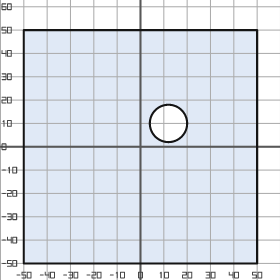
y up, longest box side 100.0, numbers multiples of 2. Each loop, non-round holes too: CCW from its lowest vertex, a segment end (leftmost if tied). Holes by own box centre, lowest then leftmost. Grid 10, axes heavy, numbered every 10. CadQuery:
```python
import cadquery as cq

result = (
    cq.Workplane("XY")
    .moveTo(-50.0, -50.0)
    .lineTo(50.0, -50.0)
    .lineTo(50.0, 50.0)
    .lineTo(-50.0, 50.0)
    .close()
    .moveTo(12.0, 10.0)
    .circle(8.0)
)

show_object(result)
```